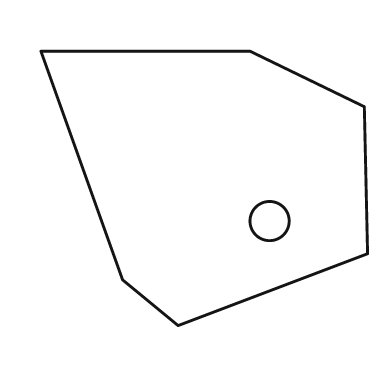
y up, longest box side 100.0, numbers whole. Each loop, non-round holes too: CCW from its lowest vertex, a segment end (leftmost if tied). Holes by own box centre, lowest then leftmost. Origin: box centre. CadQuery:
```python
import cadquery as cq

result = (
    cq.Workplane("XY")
    .moveTo(-8.0, -42.0)
    .lineTo(50.0, -20.0)
    .lineTo(49.0, 25.0)
    .lineTo(14.0, 42.0)
    .lineTo(-50.0, 42.0)
    .lineTo(-25.0, -28.0)
    .close()
    .moveTo(20.0, -10.0)
    .circle(6.0)
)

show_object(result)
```